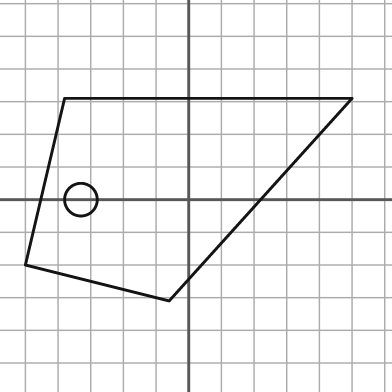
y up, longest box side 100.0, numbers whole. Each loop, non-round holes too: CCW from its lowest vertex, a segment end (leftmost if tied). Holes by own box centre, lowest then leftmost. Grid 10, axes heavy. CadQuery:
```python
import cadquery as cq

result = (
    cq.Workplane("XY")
    .moveTo(-6.0, -31.0)
    .lineTo(50.0, 31.0)
    .lineTo(-38.0, 31.0)
    .lineTo(-50.0, -20.0)
    .close()
    .moveTo(-33.0, 0.0)
    .circle(5.0)
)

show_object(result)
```